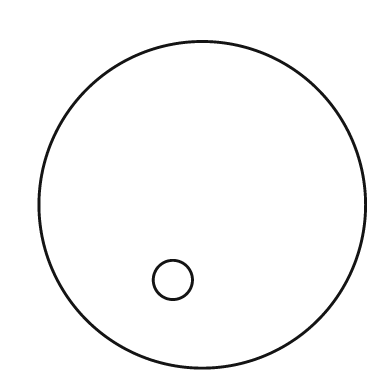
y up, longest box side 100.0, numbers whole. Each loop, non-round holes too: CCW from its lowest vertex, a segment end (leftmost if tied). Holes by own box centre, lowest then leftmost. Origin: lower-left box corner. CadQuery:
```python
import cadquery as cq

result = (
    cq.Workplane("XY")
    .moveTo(50.0, 50.0)
    .circle(50.0)
    .moveTo(41.0, 27.0)
    .circle(6.0)
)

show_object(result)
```